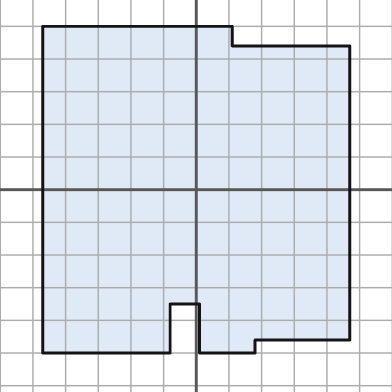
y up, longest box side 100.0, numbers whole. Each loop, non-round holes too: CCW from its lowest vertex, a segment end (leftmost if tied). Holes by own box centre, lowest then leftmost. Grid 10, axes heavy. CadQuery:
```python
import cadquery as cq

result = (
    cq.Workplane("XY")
    .moveTo(-47.0, -50.0)
    .lineTo(-8.0, -50.0)
    .lineTo(-8.0, -35.0)
    .lineTo(1.0, -35.0)
    .lineTo(1.0, -50.0)
    .lineTo(18.0, -50.0)
    .lineTo(18.0, -46.0)
    .lineTo(47.0, -46.0)
    .lineTo(47.0, 44.0)
    .lineTo(11.0, 44.0)
    .lineTo(11.0, 50.0)
    .lineTo(-47.0, 50.0)
    .close()
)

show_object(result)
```